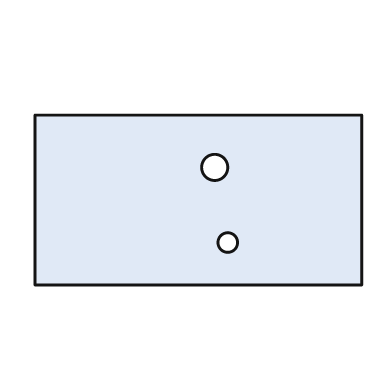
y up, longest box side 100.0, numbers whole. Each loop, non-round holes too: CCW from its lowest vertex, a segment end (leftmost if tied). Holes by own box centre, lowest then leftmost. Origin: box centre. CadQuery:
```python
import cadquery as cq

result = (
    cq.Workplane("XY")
    .moveTo(-50.0, -26.0)
    .lineTo(50.0, -26.0)
    .lineTo(50.0, 26.0)
    .lineTo(-50.0, 26.0)
    .close()
    .moveTo(9.0, -13.0)
    .circle(3.0)
    .moveTo(5.0, 10.0)
    .circle(4.0)
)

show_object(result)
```